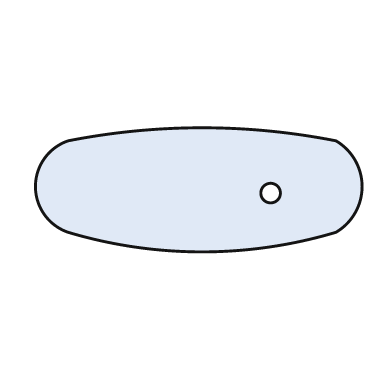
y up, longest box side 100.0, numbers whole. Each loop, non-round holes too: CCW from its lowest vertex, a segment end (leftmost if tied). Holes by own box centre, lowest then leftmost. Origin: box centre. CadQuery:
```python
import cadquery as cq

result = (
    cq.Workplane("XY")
    .moveTo(-40.0, -13.0)
    .threePointArc((1.0, -19.0), (42.0, -13.0))
    .threePointArc((50.0, 1.0), (42.0, 15.0))
    .threePointArc((1.0, 19.0), (-40.0, 15.0))
    .threePointArc((-50.0, 1.0), (-40.0, -13.0))
    .close()
    .moveTo(22.0, -1.0)
    .circle(3.0)
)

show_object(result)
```